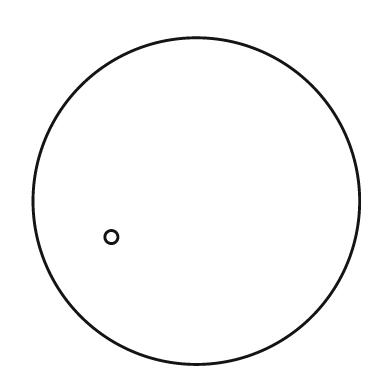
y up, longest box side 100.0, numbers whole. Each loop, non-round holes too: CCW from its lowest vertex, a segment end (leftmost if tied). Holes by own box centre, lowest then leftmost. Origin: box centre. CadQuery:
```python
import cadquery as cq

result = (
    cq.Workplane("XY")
    .moveTo(0.0, 0.0)
    .circle(50.0)
    .moveTo(-26.0, -11.0)
    .circle(2.0)
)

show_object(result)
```